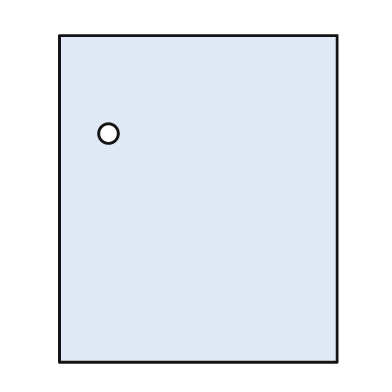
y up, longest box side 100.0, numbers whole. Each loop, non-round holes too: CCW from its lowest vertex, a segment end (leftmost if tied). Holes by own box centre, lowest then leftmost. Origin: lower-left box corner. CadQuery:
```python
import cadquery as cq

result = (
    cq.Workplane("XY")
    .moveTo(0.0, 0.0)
    .lineTo(85.0, 0.0)
    .lineTo(85.0, 100.0)
    .lineTo(0.0, 100.0)
    .close()
    .moveTo(15.0, 70.0)
    .circle(3.0)
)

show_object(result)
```